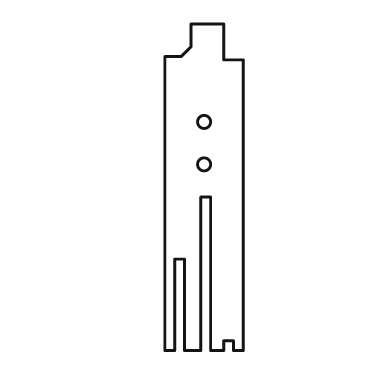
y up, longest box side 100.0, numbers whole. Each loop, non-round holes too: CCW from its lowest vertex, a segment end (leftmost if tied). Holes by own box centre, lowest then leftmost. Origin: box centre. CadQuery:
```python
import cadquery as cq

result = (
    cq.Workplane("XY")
    .moveTo(-12.0, -50.0)
    .lineTo(-9.0, -50.0)
    .lineTo(-9.0, -22.0)
    .lineTo(-6.0, -22.0)
    .lineTo(-6.0, -50.0)
    .lineTo(-1.0, -50.0)
    .lineTo(-1.0, -3.0)
    .lineTo(2.0, -3.0)
    .lineTo(2.0, -50.0)
    .lineTo(6.0, -50.0)
    .lineTo(6.0, -47.0)
    .lineTo(9.0, -47.0)
    .lineTo(9.0, -50.0)
    .lineTo(12.0, -50.0)
    .lineTo(12.0, 39.0)
    .lineTo(6.0, 39.0)
    .lineTo(6.0, 50.0)
    .lineTo(-4.0, 50.0)
    .lineTo(-4.0, 43.0)
    .lineTo(-7.0, 40.0)
    .lineTo(-12.0, 40.0)
    .close()
    .moveTo(0.0, 7.0)
    .circle(2.0)
    .moveTo(0.0, 20.0)
    .circle(2.0)
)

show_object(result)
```